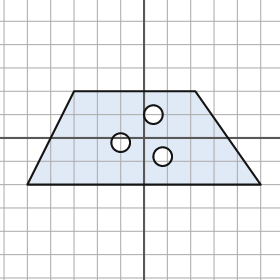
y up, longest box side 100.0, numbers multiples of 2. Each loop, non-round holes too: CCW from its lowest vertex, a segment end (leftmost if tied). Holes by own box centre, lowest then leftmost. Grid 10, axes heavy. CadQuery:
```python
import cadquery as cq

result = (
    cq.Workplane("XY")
    .moveTo(-50.0, -20.0)
    .lineTo(50.0, -20.0)
    .lineTo(22.0, 20.0)
    .lineTo(-30.0, 20.0)
    .close()
    .moveTo(8.0, -8.0)
    .circle(4.0)
    .moveTo(-10.0, -2.0)
    .circle(4.0)
    .moveTo(4.0, 10.0)
    .circle(4.0)
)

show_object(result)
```